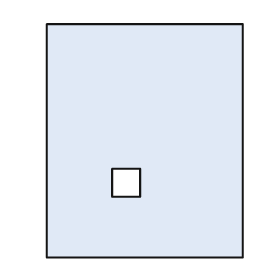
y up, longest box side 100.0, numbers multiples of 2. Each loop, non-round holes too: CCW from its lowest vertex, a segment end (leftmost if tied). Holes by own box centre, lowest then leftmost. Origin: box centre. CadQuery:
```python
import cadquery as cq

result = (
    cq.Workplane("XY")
    .moveTo(-42.0, -50.0)
    .lineTo(42.0, -50.0)
    .lineTo(42.0, 50.0)
    .lineTo(-42.0, 50.0)
    .close()
    .moveTo(-14.0, -24.0)
    .lineTo(-2.0, -24.0)
    .lineTo(-2.0, -12.0)
    .lineTo(-14.0, -12.0)
    .close()
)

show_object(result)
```